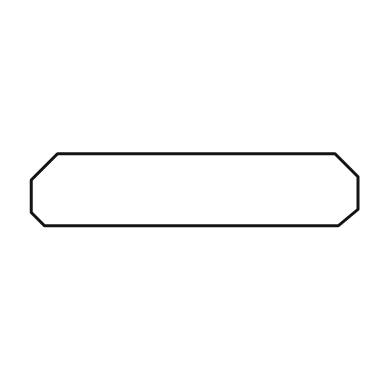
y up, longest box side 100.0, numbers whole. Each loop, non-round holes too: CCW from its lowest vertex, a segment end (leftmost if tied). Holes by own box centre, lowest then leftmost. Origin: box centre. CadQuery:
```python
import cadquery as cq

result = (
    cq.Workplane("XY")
    .moveTo(-46.0, -11.0)
    .lineTo(44.0, -11.0)
    .lineTo(50.0, -6.0)
    .lineTo(50.0, 4.0)
    .lineTo(43.0, 11.0)
    .lineTo(-42.0, 11.0)
    .lineTo(-50.0, 3.0)
    .lineTo(-50.0, -7.0)
    .close()
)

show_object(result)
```